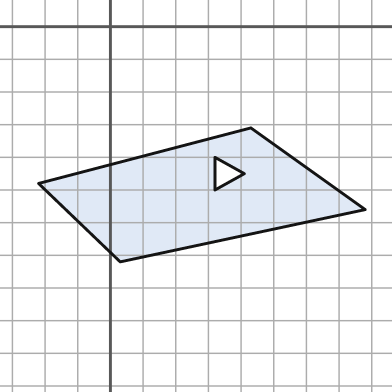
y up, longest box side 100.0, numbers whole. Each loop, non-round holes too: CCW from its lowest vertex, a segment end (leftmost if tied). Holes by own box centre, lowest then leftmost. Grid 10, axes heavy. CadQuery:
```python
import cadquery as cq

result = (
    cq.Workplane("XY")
    .moveTo(3.0, -72.0)
    .lineTo(78.0, -56.0)
    .lineTo(43.0, -31.0)
    .lineTo(-22.0, -48.0)
    .close()
    .moveTo(32.0, -50.0)
    .lineTo(41.0, -45.0)
    .lineTo(32.0, -40.0)
    .close()
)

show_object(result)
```